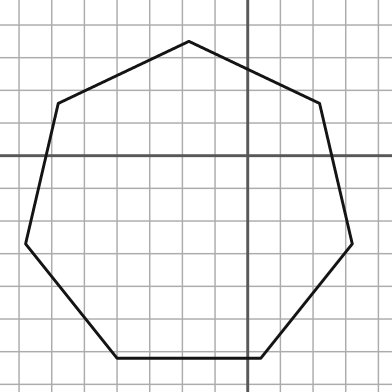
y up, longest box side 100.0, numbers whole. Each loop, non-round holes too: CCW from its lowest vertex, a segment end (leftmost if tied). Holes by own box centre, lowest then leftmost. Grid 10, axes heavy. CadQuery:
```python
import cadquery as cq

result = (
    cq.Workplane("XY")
    .moveTo(-40.0, -62.0)
    .lineTo(4.0, -62.0)
    .lineTo(32.0, -27.0)
    .lineTo(22.0, 16.0)
    .lineTo(-18.0, 35.0)
    .lineTo(-58.0, 16.0)
    .lineTo(-68.0, -27.0)
    .close()
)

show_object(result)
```